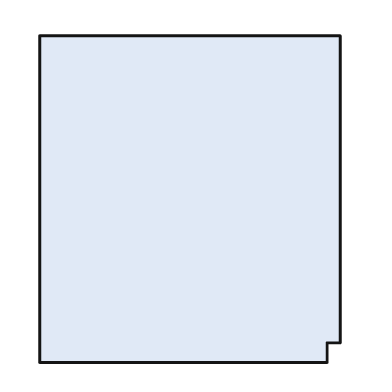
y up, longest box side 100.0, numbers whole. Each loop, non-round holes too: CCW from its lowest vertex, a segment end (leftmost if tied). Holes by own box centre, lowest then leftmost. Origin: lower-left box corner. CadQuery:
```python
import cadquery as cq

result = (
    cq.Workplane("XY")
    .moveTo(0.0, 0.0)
    .lineTo(88.0, 0.0)
    .lineTo(88.0, 6.0)
    .lineTo(92.0, 6.0)
    .lineTo(92.0, 100.0)
    .lineTo(0.0, 100.0)
    .close()
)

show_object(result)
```